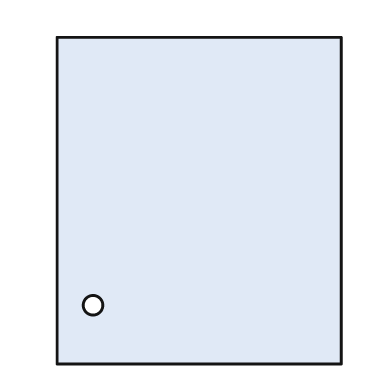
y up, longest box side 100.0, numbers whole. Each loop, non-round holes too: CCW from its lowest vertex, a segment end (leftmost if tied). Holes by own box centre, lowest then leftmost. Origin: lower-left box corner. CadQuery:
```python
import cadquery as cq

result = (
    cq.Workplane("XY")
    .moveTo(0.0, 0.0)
    .lineTo(87.0, 0.0)
    .lineTo(87.0, 100.0)
    .lineTo(0.0, 100.0)
    .close()
    .moveTo(11.0, 18.0)
    .circle(3.0)
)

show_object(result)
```